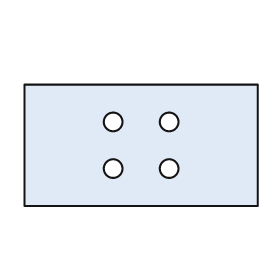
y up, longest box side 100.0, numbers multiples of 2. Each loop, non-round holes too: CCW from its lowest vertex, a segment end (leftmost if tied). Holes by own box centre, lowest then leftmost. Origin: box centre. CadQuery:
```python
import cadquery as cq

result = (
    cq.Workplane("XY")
    .moveTo(-50.0, -26.0)
    .lineTo(50.0, -26.0)
    .lineTo(50.0, 26.0)
    .lineTo(-50.0, 26.0)
    .close()
    .moveTo(-12.0, -10.0)
    .circle(4.0)
    .moveTo(12.0, -10.0)
    .circle(4.0)
    .moveTo(-12.0, 10.0)
    .circle(4.0)
    .moveTo(12.0, 10.0)
    .circle(4.0)
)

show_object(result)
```